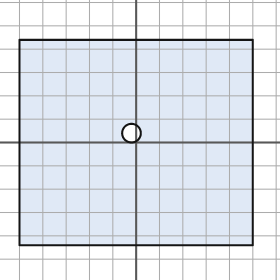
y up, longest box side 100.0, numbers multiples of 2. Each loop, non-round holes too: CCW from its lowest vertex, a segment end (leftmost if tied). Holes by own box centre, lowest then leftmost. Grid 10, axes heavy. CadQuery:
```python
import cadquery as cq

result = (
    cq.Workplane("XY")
    .moveTo(-50.0, -44.0)
    .lineTo(50.0, -44.0)
    .lineTo(50.0, 44.0)
    .lineTo(-50.0, 44.0)
    .close()
    .moveTo(-2.0, 4.0)
    .circle(4.0)
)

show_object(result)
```